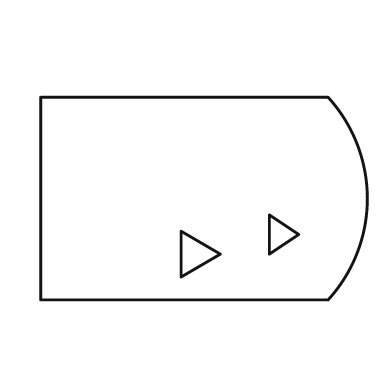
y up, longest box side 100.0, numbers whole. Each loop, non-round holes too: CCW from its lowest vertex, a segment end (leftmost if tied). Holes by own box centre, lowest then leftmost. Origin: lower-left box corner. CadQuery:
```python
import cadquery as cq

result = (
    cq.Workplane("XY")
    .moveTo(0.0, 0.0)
    .lineTo(88.0, 0.0)
    .threePointArc((100.0, 31.0), (88.0, 62.0))
    .lineTo(0.0, 62.0)
    .close()
    .moveTo(43.0, 7.0)
    .lineTo(55.0, 14.0)
    .lineTo(43.0, 21.0)
    .close()
    .moveTo(70.0, 14.0)
    .lineTo(79.0, 20.0)
    .lineTo(70.0, 26.0)
    .close()
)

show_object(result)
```